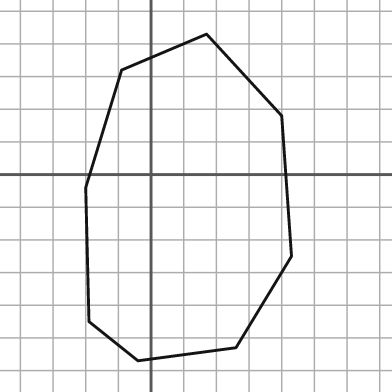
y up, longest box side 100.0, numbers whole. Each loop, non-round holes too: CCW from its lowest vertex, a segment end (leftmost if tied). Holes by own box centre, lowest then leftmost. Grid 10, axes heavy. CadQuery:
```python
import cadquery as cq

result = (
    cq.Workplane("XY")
    .moveTo(-4.0, -57.0)
    .lineTo(26.0, -53.0)
    .lineTo(43.0, -25.0)
    .lineTo(40.0, 18.0)
    .lineTo(17.0, 43.0)
    .lineTo(-9.0, 32.0)
    .lineTo(-20.0, -4.0)
    .lineTo(-19.0, -45.0)
    .close()
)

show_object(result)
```